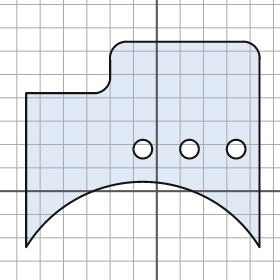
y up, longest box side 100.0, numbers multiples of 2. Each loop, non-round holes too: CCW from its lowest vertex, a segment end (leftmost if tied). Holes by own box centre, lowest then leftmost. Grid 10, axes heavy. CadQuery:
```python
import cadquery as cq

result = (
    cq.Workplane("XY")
    .moveTo(-56.0, -24.0)
    .threePointArc((-6.0, 4.0), (44.0, -24.0))
    .lineTo(44.0, 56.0)
    .threePointArc((42.0, 62.0), (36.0, 64.0))
    .lineTo(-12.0, 64.0)
    .threePointArc((-18.0, 62.0), (-20.0, 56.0))
    .lineTo(-20.0, 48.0)
    .threePointArc((-22.0, 44.0), (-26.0, 42.0))
    .lineTo(-56.0, 42.0)
    .close()
    .moveTo(-6.0, 18.0)
    .circle(4.0)
    .moveTo(14.0, 18.0)
    .circle(4.0)
    .moveTo(34.0, 18.0)
    .circle(4.0)
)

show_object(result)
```